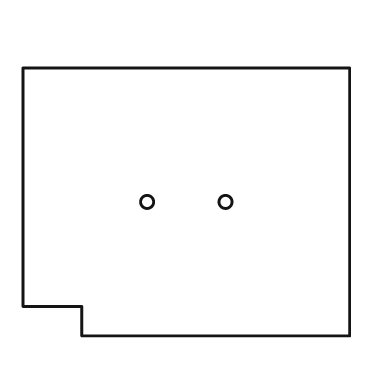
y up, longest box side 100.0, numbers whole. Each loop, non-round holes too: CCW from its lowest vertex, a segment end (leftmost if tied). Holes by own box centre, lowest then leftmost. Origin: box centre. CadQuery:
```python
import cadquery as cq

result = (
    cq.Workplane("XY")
    .moveTo(-32.0, -41.0)
    .lineTo(50.0, -41.0)
    .lineTo(50.0, 41.0)
    .lineTo(-50.0, 41.0)
    .lineTo(-50.0, -32.0)
    .lineTo(-32.0, -32.0)
    .close()
    .moveTo(-12.0, 0.0)
    .circle(2.0)
    .moveTo(12.0, 0.0)
    .circle(2.0)
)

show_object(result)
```